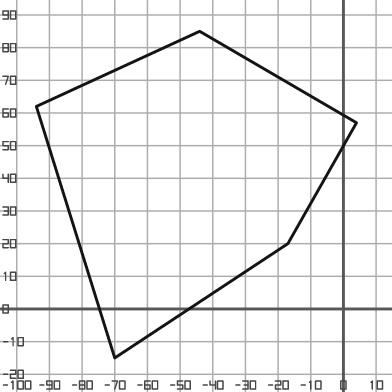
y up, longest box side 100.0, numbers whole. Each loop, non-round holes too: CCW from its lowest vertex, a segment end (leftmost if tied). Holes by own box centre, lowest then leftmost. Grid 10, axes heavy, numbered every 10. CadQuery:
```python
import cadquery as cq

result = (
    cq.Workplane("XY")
    .moveTo(-70.0, -15.0)
    .lineTo(-17.0, 20.0)
    .lineTo(4.0, 57.0)
    .lineTo(-44.0, 85.0)
    .lineTo(-94.0, 62.0)
    .close()
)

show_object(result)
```